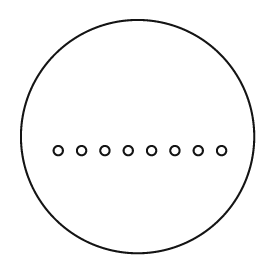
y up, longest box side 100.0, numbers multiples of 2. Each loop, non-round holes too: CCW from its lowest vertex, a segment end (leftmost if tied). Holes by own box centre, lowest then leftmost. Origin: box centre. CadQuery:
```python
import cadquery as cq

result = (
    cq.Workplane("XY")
    .moveTo(0.0, 0.0)
    .circle(50.0)
    .moveTo(-34.0, -6.0)
    .circle(2.0)
    .moveTo(-24.0, -6.0)
    .circle(2.0)
    .moveTo(-14.0, -6.0)
    .circle(2.0)
    .moveTo(-4.0, -6.0)
    .circle(2.0)
    .moveTo(6.0, -6.0)
    .circle(2.0)
    .moveTo(16.0, -6.0)
    .circle(2.0)
    .moveTo(26.0, -6.0)
    .circle(2.0)
    .moveTo(36.0, -6.0)
    .circle(2.0)
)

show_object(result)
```